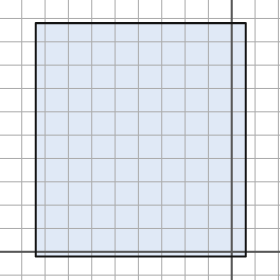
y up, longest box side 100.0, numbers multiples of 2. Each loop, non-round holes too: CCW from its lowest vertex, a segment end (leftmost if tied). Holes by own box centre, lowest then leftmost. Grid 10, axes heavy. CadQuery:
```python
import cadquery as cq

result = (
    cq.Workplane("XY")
    .moveTo(-84.0, -2.0)
    .lineTo(6.0, -2.0)
    .lineTo(6.0, 98.0)
    .lineTo(-84.0, 98.0)
    .close()
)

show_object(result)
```